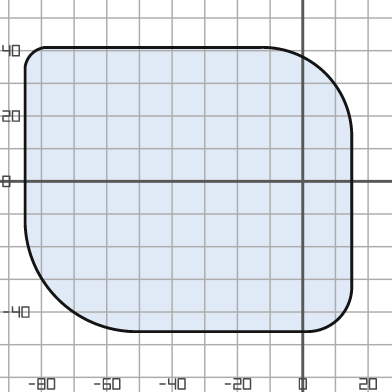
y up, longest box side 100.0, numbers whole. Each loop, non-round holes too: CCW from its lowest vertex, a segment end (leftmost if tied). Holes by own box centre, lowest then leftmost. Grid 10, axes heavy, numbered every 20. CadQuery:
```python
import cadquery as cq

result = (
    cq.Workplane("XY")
    .moveTo(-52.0, -46.0)
    .lineTo(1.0, -46.0)
    .threePointArc((11.0, -42.0), (15.0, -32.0))
    .lineTo(15.0, 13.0)
    .threePointArc((7.0, 33.0), (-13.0, 41.0))
    .lineTo(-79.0, 41.0)
    .threePointArc((-83.0, 39.0), (-85.0, 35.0))
    .lineTo(-85.0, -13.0)
    .threePointArc((-75.0, -36.0), (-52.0, -46.0))
    .close()
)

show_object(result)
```